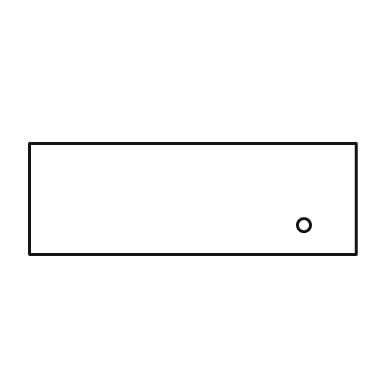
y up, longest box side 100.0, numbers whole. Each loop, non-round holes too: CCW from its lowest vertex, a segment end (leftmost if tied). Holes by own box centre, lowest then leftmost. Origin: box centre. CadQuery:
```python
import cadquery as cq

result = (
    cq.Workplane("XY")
    .moveTo(-50.0, -17.0)
    .lineTo(50.0, -17.0)
    .lineTo(50.0, 17.0)
    .lineTo(-50.0, 17.0)
    .close()
    .moveTo(34.0, -8.0)
    .circle(2.0)
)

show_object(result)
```